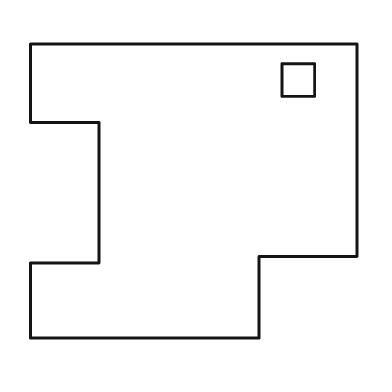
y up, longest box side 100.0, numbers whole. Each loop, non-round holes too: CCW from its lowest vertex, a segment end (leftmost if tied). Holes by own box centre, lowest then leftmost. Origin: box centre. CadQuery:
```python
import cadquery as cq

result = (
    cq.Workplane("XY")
    .moveTo(-50.0, -45.0)
    .lineTo(20.0, -45.0)
    .lineTo(20.0, -20.0)
    .lineTo(50.0, -20.0)
    .lineTo(50.0, 45.0)
    .lineTo(-50.0, 45.0)
    .lineTo(-50.0, 21.0)
    .lineTo(-29.0, 21.0)
    .lineTo(-29.0, -22.0)
    .lineTo(-50.0, -22.0)
    .close()
    .moveTo(27.0, 29.0)
    .lineTo(37.0, 29.0)
    .lineTo(37.0, 39.0)
    .lineTo(27.0, 39.0)
    .close()
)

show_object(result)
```